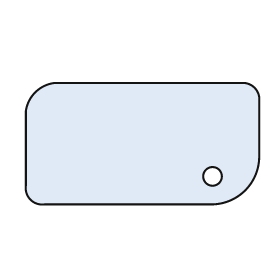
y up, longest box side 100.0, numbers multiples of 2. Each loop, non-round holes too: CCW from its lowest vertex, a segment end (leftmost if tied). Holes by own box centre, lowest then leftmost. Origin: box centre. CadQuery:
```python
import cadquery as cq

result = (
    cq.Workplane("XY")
    .moveTo(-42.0, -26.0)
    .lineTo(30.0, -26.0)
    .threePointArc((44.0, -20.0), (50.0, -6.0))
    .lineTo(50.0, 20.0)
    .threePointArc((48.0, 24.0), (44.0, 26.0))
    .lineTo(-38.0, 26.0)
    .threePointArc((-46.0, 22.0), (-50.0, 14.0))
    .lineTo(-50.0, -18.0)
    .threePointArc((-48.0, -24.0), (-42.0, -26.0))
    .close()
    .moveTo(30.0, -14.0)
    .circle(4.0)
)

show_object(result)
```